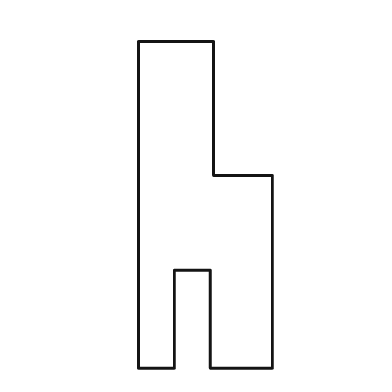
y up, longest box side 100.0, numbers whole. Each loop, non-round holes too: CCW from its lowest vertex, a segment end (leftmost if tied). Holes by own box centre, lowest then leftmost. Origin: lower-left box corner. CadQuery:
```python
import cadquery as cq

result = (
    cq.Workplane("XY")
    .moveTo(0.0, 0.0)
    .lineTo(11.0, 0.0)
    .lineTo(11.0, 30.0)
    .lineTo(22.0, 30.0)
    .lineTo(22.0, 0.0)
    .lineTo(41.0, 0.0)
    .lineTo(41.0, 59.0)
    .lineTo(23.0, 59.0)
    .lineTo(23.0, 100.0)
    .lineTo(0.0, 100.0)
    .close()
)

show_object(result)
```